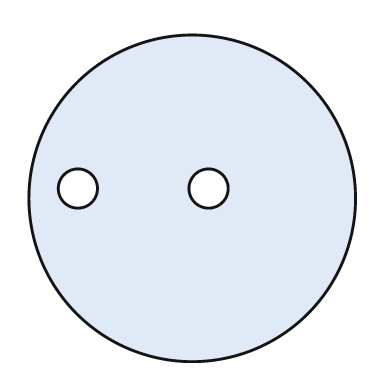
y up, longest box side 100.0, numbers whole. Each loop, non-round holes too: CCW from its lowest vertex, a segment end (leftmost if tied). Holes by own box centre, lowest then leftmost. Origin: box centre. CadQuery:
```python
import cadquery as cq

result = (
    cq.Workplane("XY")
    .moveTo(0.0, 0.0)
    .circle(50.0)
    .moveTo(-35.0, 3.0)
    .circle(6.0)
    .moveTo(5.0, 3.0)
    .circle(6.0)
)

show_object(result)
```